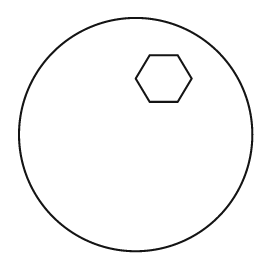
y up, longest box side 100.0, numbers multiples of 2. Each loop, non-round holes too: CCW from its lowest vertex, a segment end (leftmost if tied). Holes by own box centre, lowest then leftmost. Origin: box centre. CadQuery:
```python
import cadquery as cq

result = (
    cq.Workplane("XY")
    .moveTo(0.0, 0.0)
    .circle(50.0)
    .moveTo(6.0, 14.0)
    .lineTo(18.0, 14.0)
    .lineTo(24.0, 24.0)
    .lineTo(18.0, 34.0)
    .lineTo(6.0, 34.0)
    .lineTo(0.0, 24.0)
    .close()
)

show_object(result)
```